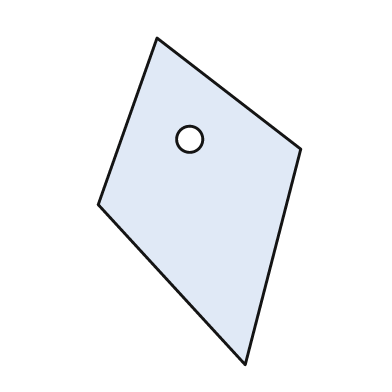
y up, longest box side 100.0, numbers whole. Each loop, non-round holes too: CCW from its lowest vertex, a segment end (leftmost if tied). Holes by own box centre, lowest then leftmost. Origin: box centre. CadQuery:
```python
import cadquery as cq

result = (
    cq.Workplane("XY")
    .moveTo(14.0, -50.0)
    .lineTo(31.0, 16.0)
    .lineTo(-13.0, 50.0)
    .lineTo(-31.0, -1.0)
    .close()
    .moveTo(-3.0, 19.0)
    .circle(4.0)
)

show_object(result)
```